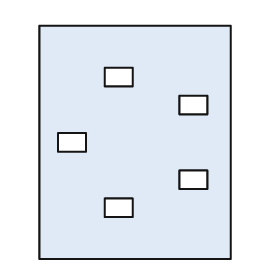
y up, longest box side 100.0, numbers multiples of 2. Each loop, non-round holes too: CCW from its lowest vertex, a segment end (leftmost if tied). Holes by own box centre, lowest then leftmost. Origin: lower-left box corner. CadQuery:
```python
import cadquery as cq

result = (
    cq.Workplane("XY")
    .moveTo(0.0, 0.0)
    .lineTo(82.0, 0.0)
    .lineTo(82.0, 100.0)
    .lineTo(0.0, 100.0)
    .close()
    .moveTo(28.0, 18.0)
    .lineTo(40.0, 18.0)
    .lineTo(40.0, 26.0)
    .lineTo(28.0, 26.0)
    .close()
    .moveTo(60.0, 30.0)
    .lineTo(72.0, 30.0)
    .lineTo(72.0, 38.0)
    .lineTo(60.0, 38.0)
    .close()
    .moveTo(8.0, 46.0)
    .lineTo(20.0, 46.0)
    .lineTo(20.0, 54.0)
    .lineTo(8.0, 54.0)
    .close()
    .moveTo(60.0, 62.0)
    .lineTo(72.0, 62.0)
    .lineTo(72.0, 70.0)
    .lineTo(60.0, 70.0)
    .close()
    .moveTo(28.0, 74.0)
    .lineTo(40.0, 74.0)
    .lineTo(40.0, 82.0)
    .lineTo(28.0, 82.0)
    .close()
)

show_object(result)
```